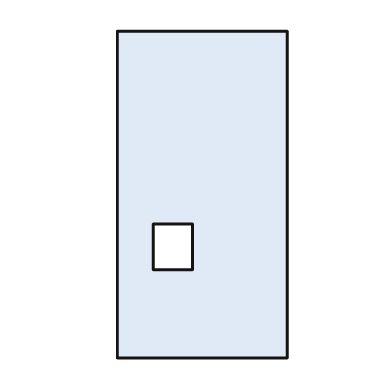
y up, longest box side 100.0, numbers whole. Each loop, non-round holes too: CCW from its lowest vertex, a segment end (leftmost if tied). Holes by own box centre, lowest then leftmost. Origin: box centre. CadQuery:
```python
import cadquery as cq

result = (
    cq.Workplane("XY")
    .moveTo(-26.0, -50.0)
    .lineTo(26.0, -50.0)
    .lineTo(26.0, 50.0)
    .lineTo(-26.0, 50.0)
    .close()
    .moveTo(-15.0, -23.0)
    .lineTo(-3.0, -23.0)
    .lineTo(-3.0, -9.0)
    .lineTo(-15.0, -9.0)
    .close()
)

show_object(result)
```